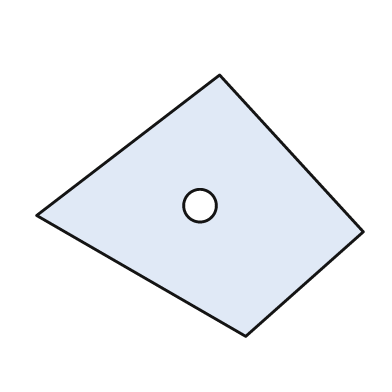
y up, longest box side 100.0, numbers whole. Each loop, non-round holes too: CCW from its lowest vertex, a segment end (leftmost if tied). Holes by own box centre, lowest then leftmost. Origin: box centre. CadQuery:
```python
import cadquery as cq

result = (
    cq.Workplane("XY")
    .moveTo(14.0, -40.0)
    .lineTo(50.0, -8.0)
    .lineTo(6.0, 40.0)
    .lineTo(-50.0, -3.0)
    .close()
    .moveTo(0.0, 0.0)
    .circle(5.0)
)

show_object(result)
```